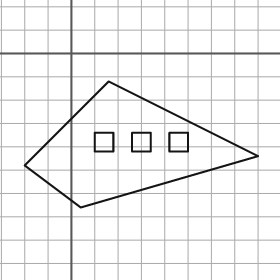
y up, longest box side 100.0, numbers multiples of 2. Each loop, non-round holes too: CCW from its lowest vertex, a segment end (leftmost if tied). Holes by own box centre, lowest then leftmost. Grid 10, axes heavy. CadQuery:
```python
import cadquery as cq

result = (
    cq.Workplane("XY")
    .moveTo(4.0, -66.0)
    .lineTo(80.0, -44.0)
    .lineTo(16.0, -12.0)
    .lineTo(-20.0, -48.0)
    .close()
    .moveTo(10.0, -42.0)
    .lineTo(18.0, -42.0)
    .lineTo(18.0, -34.0)
    .lineTo(10.0, -34.0)
    .close()
    .moveTo(26.0, -42.0)
    .lineTo(34.0, -42.0)
    .lineTo(34.0, -34.0)
    .lineTo(26.0, -34.0)
    .close()
    .moveTo(42.0, -42.0)
    .lineTo(50.0, -42.0)
    .lineTo(50.0, -34.0)
    .lineTo(42.0, -34.0)
    .close()
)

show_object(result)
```